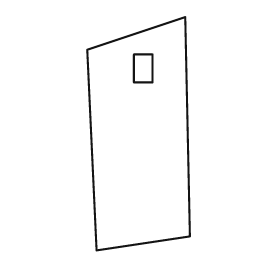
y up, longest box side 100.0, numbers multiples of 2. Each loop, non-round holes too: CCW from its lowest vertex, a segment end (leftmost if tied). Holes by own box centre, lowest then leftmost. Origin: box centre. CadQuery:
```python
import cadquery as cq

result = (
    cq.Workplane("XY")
    .moveTo(-18.0, -50.0)
    .lineTo(22.0, -44.0)
    .lineTo(20.0, 50.0)
    .lineTo(-22.0, 36.0)
    .close()
    .moveTo(-2.0, 22.0)
    .lineTo(6.0, 22.0)
    .lineTo(6.0, 34.0)
    .lineTo(-2.0, 34.0)
    .close()
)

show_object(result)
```